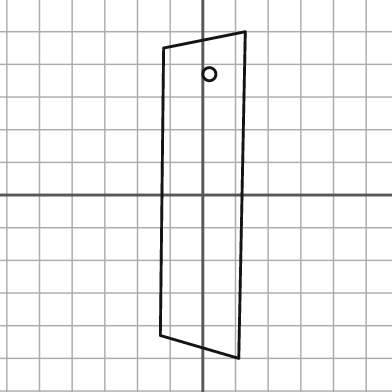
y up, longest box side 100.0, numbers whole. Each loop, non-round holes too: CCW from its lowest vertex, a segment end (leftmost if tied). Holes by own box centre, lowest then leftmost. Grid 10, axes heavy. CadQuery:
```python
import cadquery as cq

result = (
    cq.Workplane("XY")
    .moveTo(11.0, -50.0)
    .lineTo(13.0, 50.0)
    .lineTo(-12.0, 45.0)
    .lineTo(-13.0, -43.0)
    .close()
    .moveTo(2.0, 37.0)
    .circle(2.0)
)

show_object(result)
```